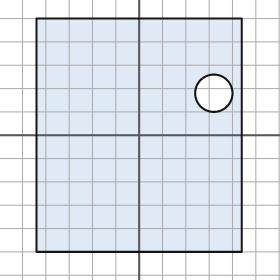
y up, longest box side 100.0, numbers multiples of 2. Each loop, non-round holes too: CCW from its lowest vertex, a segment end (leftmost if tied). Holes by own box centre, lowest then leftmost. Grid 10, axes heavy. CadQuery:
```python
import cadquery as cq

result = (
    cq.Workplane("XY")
    .moveTo(-44.0, -50.0)
    .lineTo(44.0, -50.0)
    .lineTo(44.0, 50.0)
    .lineTo(-44.0, 50.0)
    .close()
    .moveTo(32.0, 18.0)
    .circle(8.0)
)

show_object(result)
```